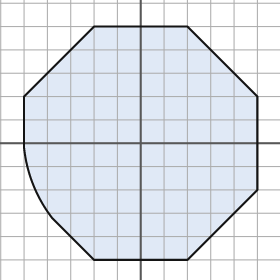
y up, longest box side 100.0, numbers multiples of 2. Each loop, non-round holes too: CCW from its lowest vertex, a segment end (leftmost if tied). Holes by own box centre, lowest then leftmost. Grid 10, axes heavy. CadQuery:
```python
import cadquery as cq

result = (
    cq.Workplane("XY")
    .moveTo(-20.0, -50.0)
    .lineTo(20.0, -50.0)
    .lineTo(50.0, -20.0)
    .lineTo(50.0, 20.0)
    .lineTo(20.0, 50.0)
    .lineTo(-20.0, 50.0)
    .lineTo(-50.0, 20.0)
    .lineTo(-50.0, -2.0)
    .threePointArc((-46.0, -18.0), (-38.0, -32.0))
    .close()
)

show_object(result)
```